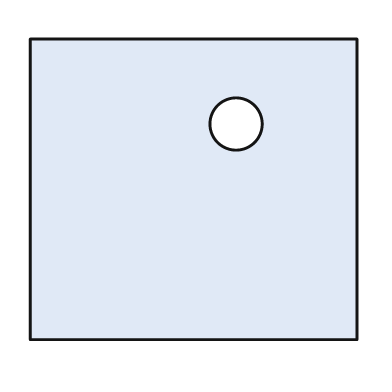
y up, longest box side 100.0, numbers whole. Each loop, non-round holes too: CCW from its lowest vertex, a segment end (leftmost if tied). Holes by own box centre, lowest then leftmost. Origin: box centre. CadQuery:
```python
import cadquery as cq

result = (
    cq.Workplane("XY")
    .moveTo(-50.0, -46.0)
    .lineTo(50.0, -46.0)
    .lineTo(50.0, 46.0)
    .lineTo(-50.0, 46.0)
    .close()
    .moveTo(13.0, 20.0)
    .circle(8.0)
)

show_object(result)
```